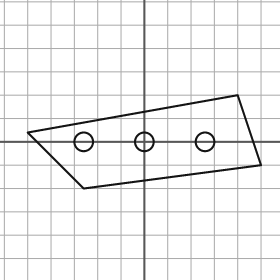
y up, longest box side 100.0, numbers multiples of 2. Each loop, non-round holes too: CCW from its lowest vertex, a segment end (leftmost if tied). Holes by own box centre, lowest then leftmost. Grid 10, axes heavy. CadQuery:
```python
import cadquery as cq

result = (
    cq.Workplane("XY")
    .moveTo(-26.0, -20.0)
    .lineTo(50.0, -10.0)
    .lineTo(40.0, 20.0)
    .lineTo(-50.0, 4.0)
    .close()
    .moveTo(-26.0, 0.0)
    .circle(4.0)
    .moveTo(0.0, 0.0)
    .circle(4.0)
    .moveTo(26.0, 0.0)
    .circle(4.0)
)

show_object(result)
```